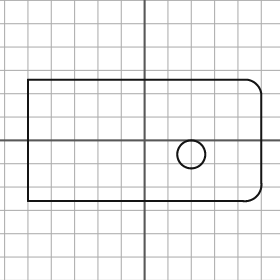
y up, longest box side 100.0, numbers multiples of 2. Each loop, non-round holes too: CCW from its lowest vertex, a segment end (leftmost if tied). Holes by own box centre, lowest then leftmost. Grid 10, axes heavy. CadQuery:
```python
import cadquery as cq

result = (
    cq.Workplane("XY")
    .moveTo(-50.0, -26.0)
    .lineTo(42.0, -26.0)
    .threePointArc((48.0, -24.0), (50.0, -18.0))
    .lineTo(50.0, 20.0)
    .threePointArc((48.0, 24.0), (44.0, 26.0))
    .lineTo(-50.0, 26.0)
    .close()
    .moveTo(20.0, -6.0)
    .circle(6.0)
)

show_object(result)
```